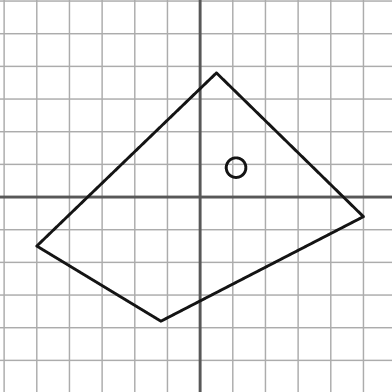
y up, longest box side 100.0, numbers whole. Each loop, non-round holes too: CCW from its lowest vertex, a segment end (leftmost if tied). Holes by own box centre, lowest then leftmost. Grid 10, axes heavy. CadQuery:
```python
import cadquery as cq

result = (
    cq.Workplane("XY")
    .moveTo(-12.0, -38.0)
    .lineTo(50.0, -6.0)
    .lineTo(5.0, 38.0)
    .lineTo(-50.0, -15.0)
    .close()
    .moveTo(11.0, 9.0)
    .circle(3.0)
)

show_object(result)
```